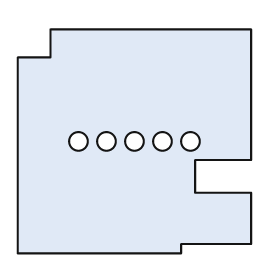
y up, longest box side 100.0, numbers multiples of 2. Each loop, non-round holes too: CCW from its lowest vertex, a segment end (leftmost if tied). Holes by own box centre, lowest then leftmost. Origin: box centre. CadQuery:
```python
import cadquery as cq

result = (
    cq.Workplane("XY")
    .moveTo(-50.0, -48.0)
    .lineTo(20.0, -48.0)
    .lineTo(20.0, -44.0)
    .lineTo(50.0, -44.0)
    .lineTo(50.0, -22.0)
    .lineTo(26.0, -22.0)
    .lineTo(26.0, -8.0)
    .lineTo(50.0, -8.0)
    .lineTo(50.0, 48.0)
    .lineTo(-36.0, 48.0)
    .lineTo(-36.0, 36.0)
    .lineTo(-50.0, 36.0)
    .close()
    .moveTo(-24.0, 0.0)
    .circle(4.0)
    .moveTo(-12.0, 0.0)
    .circle(4.0)
    .moveTo(0.0, 0.0)
    .circle(4.0)
    .moveTo(12.0, 0.0)
    .circle(4.0)
    .moveTo(24.0, 0.0)
    .circle(4.0)
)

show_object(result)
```